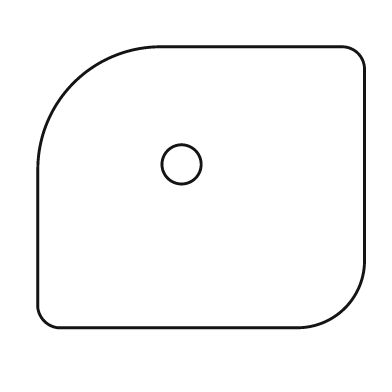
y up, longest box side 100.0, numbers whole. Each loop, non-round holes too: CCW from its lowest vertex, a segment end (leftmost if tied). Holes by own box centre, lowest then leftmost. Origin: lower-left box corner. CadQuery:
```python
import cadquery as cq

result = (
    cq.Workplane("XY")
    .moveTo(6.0, 0.0)
    .lineTo(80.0, 0.0)
    .threePointArc((94.0, 6.0), (100.0, 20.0))
    .lineTo(100.0, 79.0)
    .threePointArc((98.0, 84.0), (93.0, 86.0))
    .lineTo(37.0, 86.0)
    .threePointArc((11.0, 75.0), (0.0, 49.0))
    .lineTo(0.0, 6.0)
    .threePointArc((2.0, 2.0), (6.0, 0.0))
    .close()
    .moveTo(44.0, 50.0)
    .circle(6.0)
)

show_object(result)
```